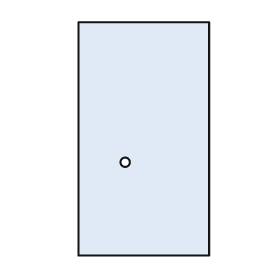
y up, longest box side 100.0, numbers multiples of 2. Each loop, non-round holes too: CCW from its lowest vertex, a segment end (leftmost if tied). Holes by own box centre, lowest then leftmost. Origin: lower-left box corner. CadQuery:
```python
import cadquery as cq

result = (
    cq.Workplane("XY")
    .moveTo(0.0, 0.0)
    .lineTo(56.0, 0.0)
    .lineTo(56.0, 100.0)
    .lineTo(0.0, 100.0)
    .close()
    .moveTo(20.0, 40.0)
    .circle(2.0)
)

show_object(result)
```